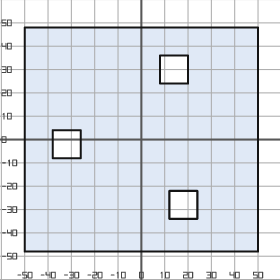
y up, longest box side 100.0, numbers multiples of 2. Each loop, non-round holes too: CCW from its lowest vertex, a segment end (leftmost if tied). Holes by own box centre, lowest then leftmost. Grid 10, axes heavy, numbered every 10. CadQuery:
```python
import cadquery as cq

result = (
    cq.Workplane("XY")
    .moveTo(-50.0, -48.0)
    .lineTo(50.0, -48.0)
    .lineTo(50.0, 48.0)
    .lineTo(-50.0, 48.0)
    .close()
    .moveTo(12.0, -34.0)
    .lineTo(24.0, -34.0)
    .lineTo(24.0, -22.0)
    .lineTo(12.0, -22.0)
    .close()
    .moveTo(-38.0, -8.0)
    .lineTo(-26.0, -8.0)
    .lineTo(-26.0, 4.0)
    .lineTo(-38.0, 4.0)
    .close()
    .moveTo(8.0, 24.0)
    .lineTo(20.0, 24.0)
    .lineTo(20.0, 36.0)
    .lineTo(8.0, 36.0)
    .close()
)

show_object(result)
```